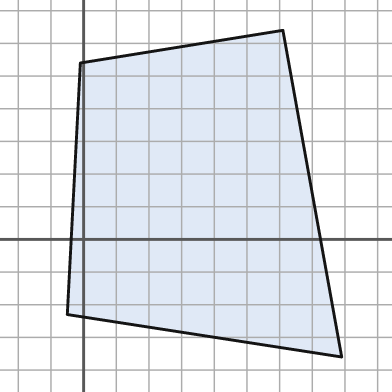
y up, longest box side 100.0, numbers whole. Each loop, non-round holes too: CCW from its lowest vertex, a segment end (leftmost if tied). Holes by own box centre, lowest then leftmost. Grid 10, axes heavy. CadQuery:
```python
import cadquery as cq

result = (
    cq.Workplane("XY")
    .moveTo(79.0, -36.0)
    .lineTo(61.0, 64.0)
    .lineTo(-1.0, 54.0)
    .lineTo(-5.0, -23.0)
    .close()
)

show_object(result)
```